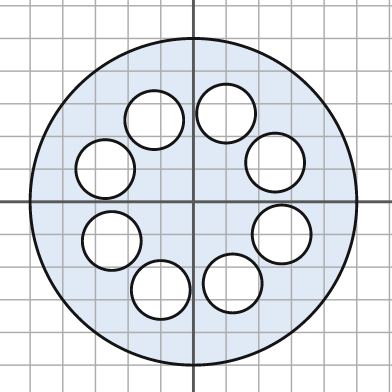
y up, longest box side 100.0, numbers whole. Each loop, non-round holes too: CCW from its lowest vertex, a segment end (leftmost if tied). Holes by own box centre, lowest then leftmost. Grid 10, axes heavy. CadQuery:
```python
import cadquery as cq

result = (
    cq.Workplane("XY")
    .moveTo(0.0, 0.0)
    .circle(50.0)
    .moveTo(-10.0, -27.0)
    .circle(9.0)
    .moveTo(12.0, -25.0)
    .circle(9.0)
    .moveTo(-25.0, -12.0)
    .circle(9.0)
    .moveTo(27.0, -10.0)
    .circle(9.0)
    .moveTo(-27.0, 10.0)
    .circle(9.0)
    .moveTo(25.0, 12.0)
    .circle(9.0)
    .moveTo(-12.0, 25.0)
    .circle(9.0)
    .moveTo(10.0, 27.0)
    .circle(9.0)
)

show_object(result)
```